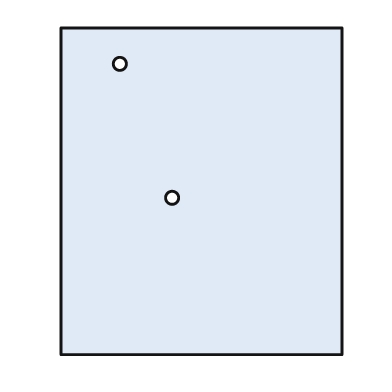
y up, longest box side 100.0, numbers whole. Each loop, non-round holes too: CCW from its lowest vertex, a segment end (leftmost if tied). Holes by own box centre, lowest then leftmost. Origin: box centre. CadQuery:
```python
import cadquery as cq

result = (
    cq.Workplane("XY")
    .moveTo(-43.0, -50.0)
    .lineTo(43.0, -50.0)
    .lineTo(43.0, 50.0)
    .lineTo(-43.0, 50.0)
    .close()
    .moveTo(-9.0, -2.0)
    .circle(2.0)
    .moveTo(-25.0, 39.0)
    .circle(2.0)
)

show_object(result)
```